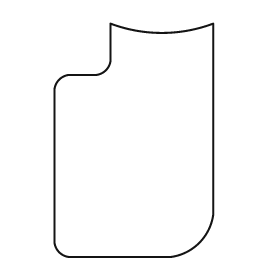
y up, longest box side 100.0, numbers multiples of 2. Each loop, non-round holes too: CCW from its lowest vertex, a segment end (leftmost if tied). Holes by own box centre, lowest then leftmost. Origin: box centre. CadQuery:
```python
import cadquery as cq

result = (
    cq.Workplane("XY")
    .moveTo(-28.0, -50.0)
    .lineTo(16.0, -50.0)
    .threePointArc((28.0, -44.0), (34.0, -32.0))
    .lineTo(34.0, 50.0)
    .threePointArc((12.0, 46.0), (-10.0, 50.0))
    .lineTo(-10.0, 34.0)
    .threePointArc((-12.0, 30.0), (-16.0, 28.0))
    .lineTo(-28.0, 28.0)
    .threePointArc((-32.0, 26.0), (-34.0, 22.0))
    .lineTo(-34.0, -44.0)
    .threePointArc((-32.0, -48.0), (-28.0, -50.0))
    .close()
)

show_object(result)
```